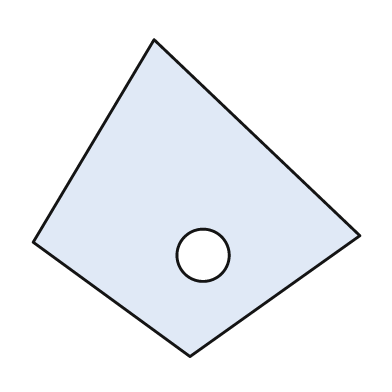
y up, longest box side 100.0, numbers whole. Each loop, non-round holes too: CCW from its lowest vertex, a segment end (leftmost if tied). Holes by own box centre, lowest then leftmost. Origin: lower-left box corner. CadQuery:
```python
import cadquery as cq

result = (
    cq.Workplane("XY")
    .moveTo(48.0, 0.0)
    .lineTo(100.0, 37.0)
    .lineTo(37.0, 97.0)
    .lineTo(0.0, 35.0)
    .close()
    .moveTo(52.0, 31.0)
    .circle(8.0)
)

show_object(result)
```